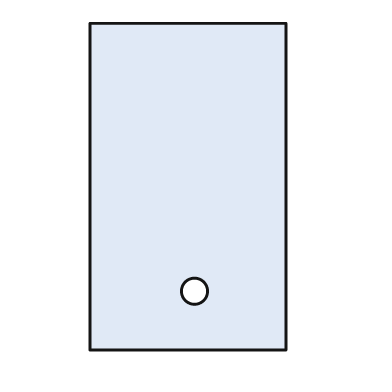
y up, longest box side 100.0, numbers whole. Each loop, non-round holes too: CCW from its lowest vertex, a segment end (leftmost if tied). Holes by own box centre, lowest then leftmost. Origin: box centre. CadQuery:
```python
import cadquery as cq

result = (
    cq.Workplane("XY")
    .moveTo(-30.0, -50.0)
    .lineTo(30.0, -50.0)
    .lineTo(30.0, 50.0)
    .lineTo(-30.0, 50.0)
    .close()
    .moveTo(2.0, -32.0)
    .circle(4.0)
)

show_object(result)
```